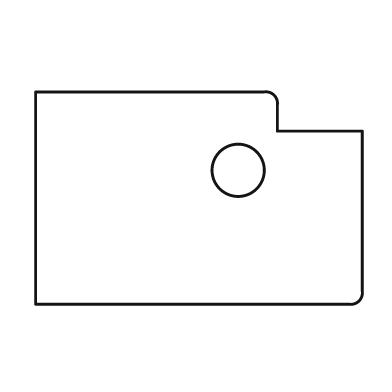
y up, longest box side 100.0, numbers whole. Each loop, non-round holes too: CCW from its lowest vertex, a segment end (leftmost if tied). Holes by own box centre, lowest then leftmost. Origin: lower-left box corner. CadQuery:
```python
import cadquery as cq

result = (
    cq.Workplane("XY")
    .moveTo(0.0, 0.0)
    .lineTo(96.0, 0.0)
    .threePointArc((99.0, 1.0), (100.0, 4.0))
    .lineTo(100.0, 53.0)
    .lineTo(74.0, 53.0)
    .lineTo(74.0, 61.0)
    .threePointArc((73.0, 64.0), (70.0, 65.0))
    .lineTo(0.0, 65.0)
    .close()
    .moveTo(62.0, 41.0)
    .circle(8.0)
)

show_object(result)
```